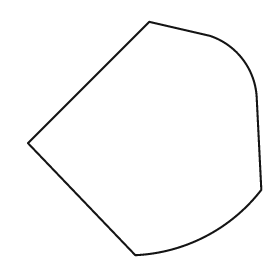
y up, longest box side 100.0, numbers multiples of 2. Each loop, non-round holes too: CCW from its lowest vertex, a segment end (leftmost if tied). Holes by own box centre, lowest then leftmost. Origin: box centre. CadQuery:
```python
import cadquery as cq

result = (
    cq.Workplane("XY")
    .moveTo(-4.0, -50.0)
    .threePointArc((26.0, -42.0), (50.0, -22.0))
    .lineTo(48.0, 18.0)
    .threePointArc((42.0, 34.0), (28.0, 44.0))
    .lineTo(2.0, 50.0)
    .lineTo(-50.0, -2.0)
    .close()
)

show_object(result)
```